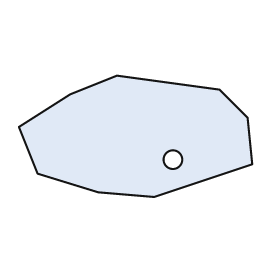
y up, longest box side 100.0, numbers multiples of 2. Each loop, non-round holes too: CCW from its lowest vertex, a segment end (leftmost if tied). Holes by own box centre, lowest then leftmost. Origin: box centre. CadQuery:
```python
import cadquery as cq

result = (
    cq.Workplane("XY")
    .moveTo(8.0, -26.0)
    .lineTo(50.0, -12.0)
    .lineTo(48.0, 8.0)
    .lineTo(36.0, 20.0)
    .lineTo(-8.0, 26.0)
    .lineTo(-28.0, 18.0)
    .lineTo(-50.0, 4.0)
    .lineTo(-42.0, -16.0)
    .lineTo(-16.0, -24.0)
    .close()
    .moveTo(16.0, -10.0)
    .circle(4.0)
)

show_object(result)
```